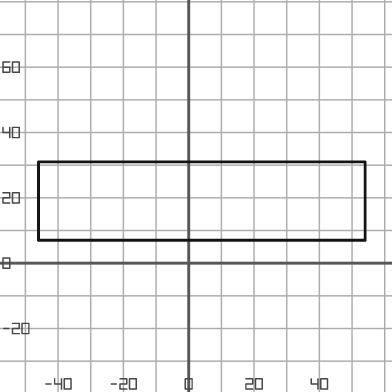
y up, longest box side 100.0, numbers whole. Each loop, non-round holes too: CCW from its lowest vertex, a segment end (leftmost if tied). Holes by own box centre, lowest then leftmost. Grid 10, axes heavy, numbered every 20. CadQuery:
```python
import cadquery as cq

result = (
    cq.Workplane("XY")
    .moveTo(-46.0, 7.0)
    .lineTo(54.0, 7.0)
    .lineTo(54.0, 31.0)
    .lineTo(-46.0, 31.0)
    .close()
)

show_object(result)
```